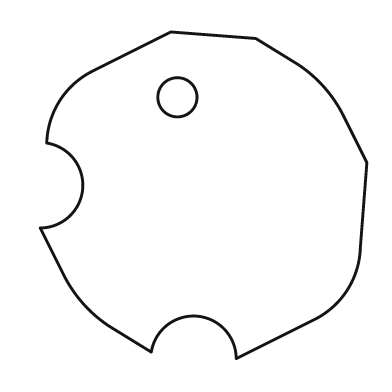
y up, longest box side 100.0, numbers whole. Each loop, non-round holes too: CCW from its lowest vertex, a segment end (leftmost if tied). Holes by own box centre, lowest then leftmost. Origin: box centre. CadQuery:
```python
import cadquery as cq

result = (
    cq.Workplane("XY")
    .moveTo(10.0, -50.0)
    .lineTo(34.0, -38.0)
    .threePointArc((44.0, -29.0), (48.0, -16.0))
    .lineTo(50.0, 10.0)
    .lineTo(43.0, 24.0)
    .threePointArc((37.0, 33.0), (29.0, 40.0))
    .lineTo(16.0, 48.0)
    .lineTo(-10.0, 50.0)
    .lineTo(-34.0, 38.0)
    .threePointArc((-44.0, 29.0), (-48.0, 16.0))
    .threePointArc((-37.0, 2.0), (-50.0, -10.0))
    .lineTo(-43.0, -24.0)
    .threePointArc((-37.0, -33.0), (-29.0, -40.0))
    .lineTo(-16.0, -48.0)
    .threePointArc((-2.0, -37.0), (10.0, -50.0))
    .close()
    .moveTo(-8.0, 30.0)
    .circle(6.0)
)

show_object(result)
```